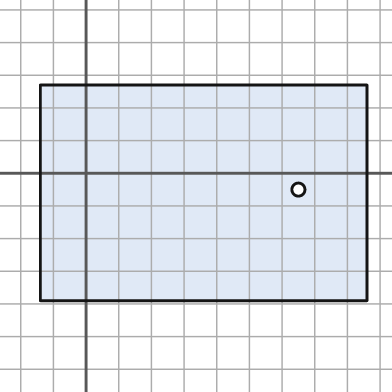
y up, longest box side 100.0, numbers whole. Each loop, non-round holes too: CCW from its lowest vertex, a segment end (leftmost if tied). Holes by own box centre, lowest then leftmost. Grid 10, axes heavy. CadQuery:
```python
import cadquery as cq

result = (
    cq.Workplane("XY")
    .moveTo(-14.0, -39.0)
    .lineTo(86.0, -39.0)
    .lineTo(86.0, 27.0)
    .lineTo(-14.0, 27.0)
    .close()
    .moveTo(65.0, -5.0)
    .circle(2.0)
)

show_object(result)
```